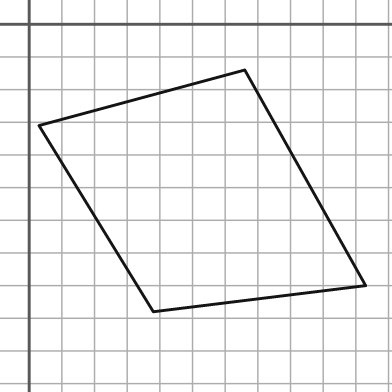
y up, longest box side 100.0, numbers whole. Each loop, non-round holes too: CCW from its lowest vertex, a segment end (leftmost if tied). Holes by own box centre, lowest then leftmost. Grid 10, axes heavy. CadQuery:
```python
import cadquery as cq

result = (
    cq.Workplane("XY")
    .moveTo(38.0, -88.0)
    .lineTo(103.0, -80.0)
    .lineTo(66.0, -14.0)
    .lineTo(3.0, -31.0)
    .close()
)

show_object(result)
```